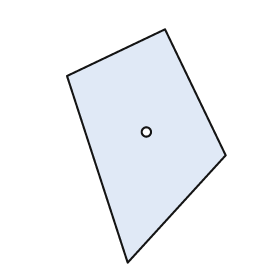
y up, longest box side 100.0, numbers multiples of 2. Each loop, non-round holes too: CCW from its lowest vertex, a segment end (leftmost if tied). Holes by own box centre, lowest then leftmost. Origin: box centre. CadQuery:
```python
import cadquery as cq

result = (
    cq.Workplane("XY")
    .moveTo(-8.0, -50.0)
    .lineTo(34.0, -4.0)
    .lineTo(8.0, 50.0)
    .lineTo(-34.0, 30.0)
    .close()
    .moveTo(0.0, 6.0)
    .circle(2.0)
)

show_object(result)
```